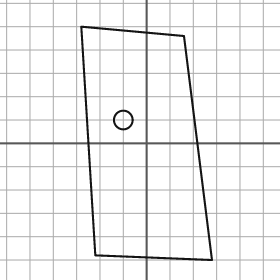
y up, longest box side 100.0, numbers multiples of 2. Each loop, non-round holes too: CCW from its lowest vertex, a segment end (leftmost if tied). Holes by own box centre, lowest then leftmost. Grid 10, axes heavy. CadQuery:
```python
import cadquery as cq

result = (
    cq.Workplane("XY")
    .moveTo(28.0, -50.0)
    .lineTo(16.0, 46.0)
    .lineTo(-28.0, 50.0)
    .lineTo(-22.0, -48.0)
    .close()
    .moveTo(-10.0, 10.0)
    .circle(4.0)
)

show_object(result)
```